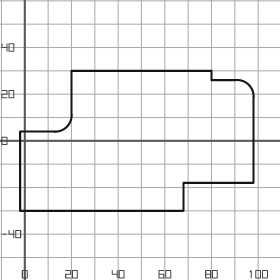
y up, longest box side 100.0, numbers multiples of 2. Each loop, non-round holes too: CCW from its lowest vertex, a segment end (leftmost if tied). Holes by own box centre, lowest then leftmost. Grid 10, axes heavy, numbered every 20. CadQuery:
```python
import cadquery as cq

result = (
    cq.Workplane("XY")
    .moveTo(-2.0, -30.0)
    .lineTo(68.0, -30.0)
    .lineTo(68.0, -18.0)
    .lineTo(98.0, -18.0)
    .lineTo(98.0, 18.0)
    .threePointArc((96.0, 24.0), (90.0, 26.0))
    .lineTo(80.0, 26.0)
    .lineTo(80.0, 30.0)
    .lineTo(20.0, 30.0)
    .lineTo(20.0, 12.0)
    .threePointArc((18.0, 6.0), (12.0, 4.0))
    .lineTo(-2.0, 4.0)
    .close()
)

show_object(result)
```